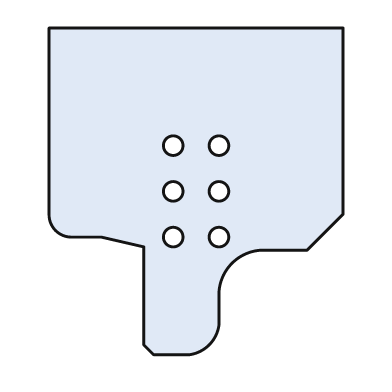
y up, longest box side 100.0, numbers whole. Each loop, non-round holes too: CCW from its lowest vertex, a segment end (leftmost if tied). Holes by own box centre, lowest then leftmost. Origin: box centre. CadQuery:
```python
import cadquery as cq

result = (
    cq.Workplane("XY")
    .moveTo(-13.0, -50.0)
    .lineTo(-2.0, -50.0)
    .threePointArc((4.0, -47.0), (7.0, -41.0))
    .lineTo(7.0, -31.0)
    .threePointArc((11.0, -22.0), (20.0, -18.0))
    .lineTo(34.0, -18.0)
    .lineTo(45.0, -7.0)
    .lineTo(45.0, 50.0)
    .lineTo(-45.0, 50.0)
    .lineTo(-45.0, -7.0)
    .threePointArc((-43.0, -12.0), (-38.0, -14.0))
    .lineTo(-29.0, -14.0)
    .lineTo(-16.0, -17.0)
    .lineTo(-16.0, -47.0)
    .close()
    .moveTo(-7.0, -14.0)
    .circle(3.0)
    .moveTo(7.0, -14.0)
    .circle(3.0)
    .moveTo(-7.0, 0.0)
    .circle(3.0)
    .moveTo(7.0, 0.0)
    .circle(3.0)
    .moveTo(-7.0, 14.0)
    .circle(3.0)
    .moveTo(7.0, 14.0)
    .circle(3.0)
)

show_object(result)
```